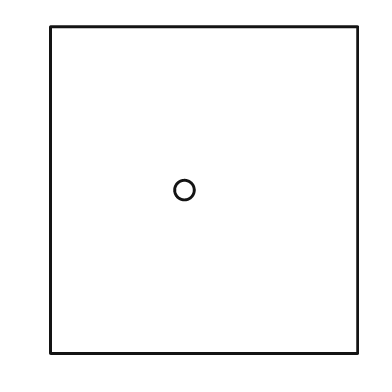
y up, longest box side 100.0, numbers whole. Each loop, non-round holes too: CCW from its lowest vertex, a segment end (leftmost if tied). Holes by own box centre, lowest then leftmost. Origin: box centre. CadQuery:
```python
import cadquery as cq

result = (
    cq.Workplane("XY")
    .moveTo(-47.0, -50.0)
    .lineTo(47.0, -50.0)
    .lineTo(47.0, 50.0)
    .lineTo(-47.0, 50.0)
    .close()
    .moveTo(-6.0, 0.0)
    .circle(3.0)
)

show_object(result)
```